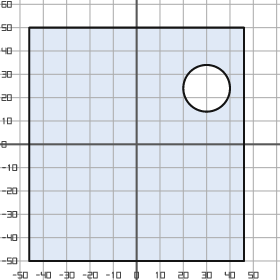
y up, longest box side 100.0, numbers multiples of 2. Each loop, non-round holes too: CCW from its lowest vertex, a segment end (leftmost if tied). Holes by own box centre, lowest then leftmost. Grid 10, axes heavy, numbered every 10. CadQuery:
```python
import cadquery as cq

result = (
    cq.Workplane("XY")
    .moveTo(-46.0, -50.0)
    .lineTo(46.0, -50.0)
    .lineTo(46.0, 50.0)
    .lineTo(-46.0, 50.0)
    .close()
    .moveTo(30.0, 24.0)
    .circle(10.0)
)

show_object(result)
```